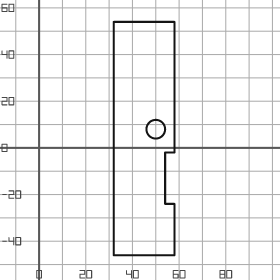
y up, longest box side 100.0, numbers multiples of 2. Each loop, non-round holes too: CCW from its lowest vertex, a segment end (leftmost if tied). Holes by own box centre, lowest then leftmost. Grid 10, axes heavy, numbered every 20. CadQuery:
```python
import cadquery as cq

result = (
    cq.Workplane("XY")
    .moveTo(32.0, -46.0)
    .lineTo(58.0, -46.0)
    .lineTo(58.0, -24.0)
    .lineTo(54.0, -24.0)
    .lineTo(54.0, -2.0)
    .lineTo(58.0, -2.0)
    .lineTo(58.0, 54.0)
    .lineTo(32.0, 54.0)
    .close()
    .moveTo(50.0, 8.0)
    .circle(4.0)
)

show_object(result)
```